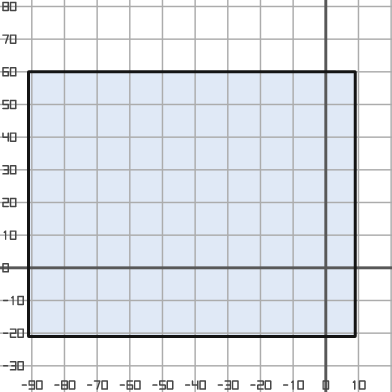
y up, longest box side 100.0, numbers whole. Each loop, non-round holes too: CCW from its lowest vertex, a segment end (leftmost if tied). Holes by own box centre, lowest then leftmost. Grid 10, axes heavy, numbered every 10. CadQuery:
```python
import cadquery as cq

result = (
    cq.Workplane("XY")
    .moveTo(-91.0, -21.0)
    .lineTo(9.0, -21.0)
    .lineTo(9.0, 60.0)
    .lineTo(-91.0, 60.0)
    .close()
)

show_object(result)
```